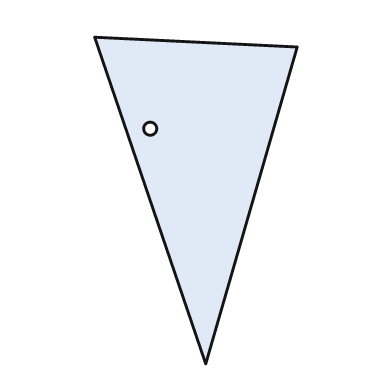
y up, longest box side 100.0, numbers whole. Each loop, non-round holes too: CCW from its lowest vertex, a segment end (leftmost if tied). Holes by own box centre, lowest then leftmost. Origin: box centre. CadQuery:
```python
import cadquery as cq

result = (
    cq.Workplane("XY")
    .moveTo(3.0, -50.0)
    .lineTo(31.0, 47.0)
    .lineTo(-31.0, 50.0)
    .close()
    .moveTo(-14.0, 22.0)
    .circle(2.0)
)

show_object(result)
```